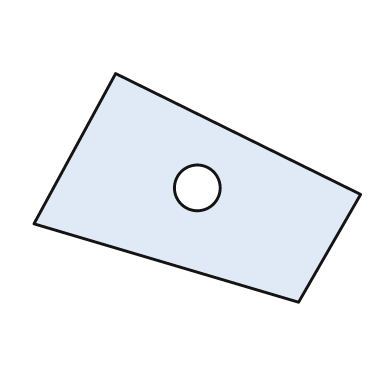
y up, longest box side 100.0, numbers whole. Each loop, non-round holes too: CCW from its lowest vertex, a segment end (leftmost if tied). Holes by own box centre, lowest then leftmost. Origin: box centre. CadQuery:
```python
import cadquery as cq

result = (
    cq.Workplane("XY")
    .moveTo(31.0, -35.0)
    .lineTo(50.0, -2.0)
    .lineTo(-25.0, 35.0)
    .lineTo(-50.0, -11.0)
    .close()
    .moveTo(0.0, 0.0)
    .circle(7.0)
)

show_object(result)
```